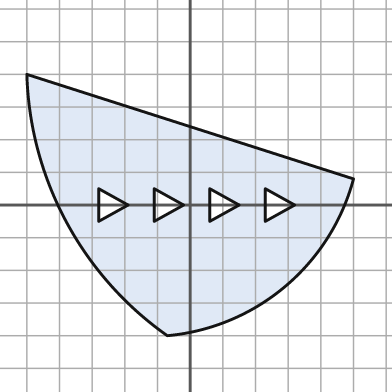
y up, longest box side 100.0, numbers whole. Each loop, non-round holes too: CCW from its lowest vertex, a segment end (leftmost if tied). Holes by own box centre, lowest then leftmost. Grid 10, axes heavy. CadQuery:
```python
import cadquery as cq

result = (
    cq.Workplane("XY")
    .moveTo(-7.0, -40.0)
    .threePointArc((29.0, -25.0), (50.0, 8.0))
    .lineTo(-50.0, 40.0)
    .threePointArc((-38.0, -5.0), (-7.0, -40.0))
    .close()
    .moveTo(-28.0, -5.0)
    .lineTo(-19.0, 0.0)
    .lineTo(-28.0, 5.0)
    .close()
    .moveTo(-11.0, -5.0)
    .lineTo(-2.0, 0.0)
    .lineTo(-11.0, 5.0)
    .close()
    .moveTo(6.0, -5.0)
    .lineTo(15.0, 0.0)
    .lineTo(6.0, 5.0)
    .close()
    .moveTo(23.0, -5.0)
    .lineTo(32.0, 0.0)
    .lineTo(23.0, 5.0)
    .close()
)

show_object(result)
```